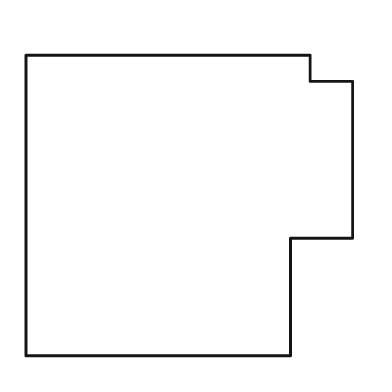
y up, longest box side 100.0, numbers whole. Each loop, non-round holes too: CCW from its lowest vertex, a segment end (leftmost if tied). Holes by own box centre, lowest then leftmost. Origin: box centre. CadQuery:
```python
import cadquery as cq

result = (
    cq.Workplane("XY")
    .moveTo(-50.0, -46.0)
    .lineTo(31.0, -46.0)
    .lineTo(31.0, -10.0)
    .lineTo(50.0, -10.0)
    .lineTo(50.0, 38.0)
    .lineTo(37.0, 38.0)
    .lineTo(37.0, 46.0)
    .lineTo(-50.0, 46.0)
    .close()
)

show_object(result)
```